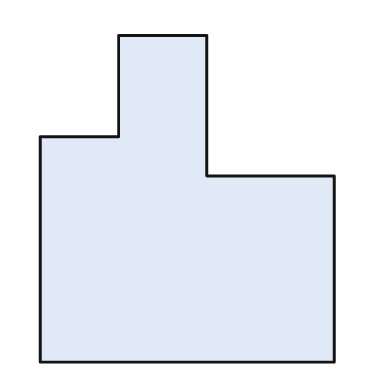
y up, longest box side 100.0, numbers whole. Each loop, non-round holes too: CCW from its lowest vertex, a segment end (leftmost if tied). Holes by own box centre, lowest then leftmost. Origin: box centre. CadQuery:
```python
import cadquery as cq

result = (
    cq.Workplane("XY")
    .moveTo(-45.0, -50.0)
    .lineTo(45.0, -50.0)
    .lineTo(45.0, 7.0)
    .lineTo(6.0, 7.0)
    .lineTo(6.0, 50.0)
    .lineTo(-21.0, 50.0)
    .lineTo(-21.0, 19.0)
    .lineTo(-45.0, 19.0)
    .close()
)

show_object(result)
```